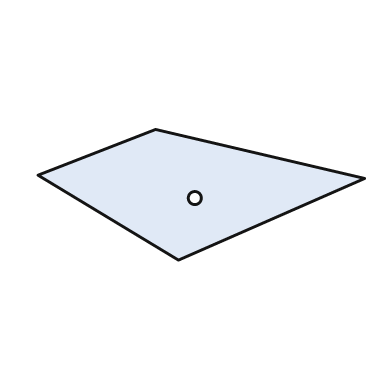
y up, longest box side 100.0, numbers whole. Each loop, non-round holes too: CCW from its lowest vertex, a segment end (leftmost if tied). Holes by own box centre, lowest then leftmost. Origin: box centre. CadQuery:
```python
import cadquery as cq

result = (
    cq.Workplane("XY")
    .moveTo(-7.0, -20.0)
    .lineTo(50.0, 5.0)
    .lineTo(-14.0, 20.0)
    .lineTo(-50.0, 6.0)
    .close()
    .moveTo(-2.0, -1.0)
    .circle(2.0)
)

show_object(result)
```